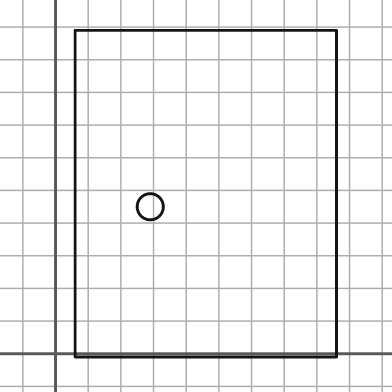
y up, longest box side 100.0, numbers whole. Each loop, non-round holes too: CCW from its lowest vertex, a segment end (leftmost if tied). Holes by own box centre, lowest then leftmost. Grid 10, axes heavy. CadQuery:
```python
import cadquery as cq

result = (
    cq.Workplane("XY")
    .moveTo(6.0, -1.0)
    .lineTo(86.0, -1.0)
    .lineTo(86.0, 99.0)
    .lineTo(6.0, 99.0)
    .close()
    .moveTo(29.0, 45.0)
    .circle(4.0)
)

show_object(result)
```